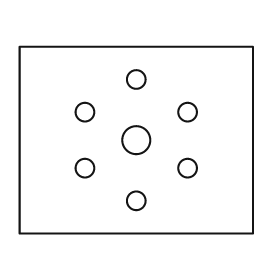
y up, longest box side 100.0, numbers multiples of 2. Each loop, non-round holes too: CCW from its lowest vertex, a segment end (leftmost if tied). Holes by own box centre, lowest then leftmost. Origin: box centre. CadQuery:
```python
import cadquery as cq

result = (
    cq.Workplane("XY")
    .moveTo(-50.0, -40.0)
    .lineTo(50.0, -40.0)
    .lineTo(50.0, 40.0)
    .lineTo(-50.0, 40.0)
    .close()
    .moveTo(0.0, -26.0)
    .circle(4.0)
    .moveTo(-22.0, -12.0)
    .circle(4.0)
    .moveTo(22.0, -12.0)
    .circle(4.0)
    .moveTo(0.0, 0.0)
    .circle(6.0)
    .moveTo(-22.0, 12.0)
    .circle(4.0)
    .moveTo(22.0, 12.0)
    .circle(4.0)
    .moveTo(0.0, 26.0)
    .circle(4.0)
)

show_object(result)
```